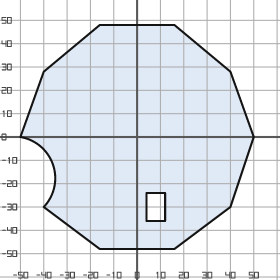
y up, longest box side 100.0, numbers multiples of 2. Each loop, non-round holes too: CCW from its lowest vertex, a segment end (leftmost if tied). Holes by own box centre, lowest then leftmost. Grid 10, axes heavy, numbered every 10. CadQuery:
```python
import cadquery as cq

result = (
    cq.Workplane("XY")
    .moveTo(-16.0, -48.0)
    .lineTo(16.0, -48.0)
    .lineTo(40.0, -30.0)
    .lineTo(50.0, 0.0)
    .lineTo(40.0, 28.0)
    .lineTo(16.0, 48.0)
    .lineTo(-16.0, 48.0)
    .lineTo(-40.0, 28.0)
    .lineTo(-50.0, 0.0)
    .threePointArc((-36.0, -12.0), (-40.0, -30.0))
    .close()
    .moveTo(4.0, -36.0)
    .lineTo(12.0, -36.0)
    .lineTo(12.0, -24.0)
    .lineTo(4.0, -24.0)
    .close()
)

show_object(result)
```